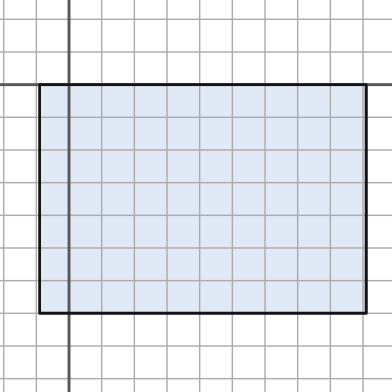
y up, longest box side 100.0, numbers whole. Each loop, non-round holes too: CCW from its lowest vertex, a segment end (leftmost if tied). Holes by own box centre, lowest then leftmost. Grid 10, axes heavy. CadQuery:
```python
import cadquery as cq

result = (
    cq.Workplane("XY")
    .moveTo(-9.0, -70.0)
    .lineTo(91.0, -70.0)
    .lineTo(91.0, 0.0)
    .lineTo(-9.0, 0.0)
    .close()
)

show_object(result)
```